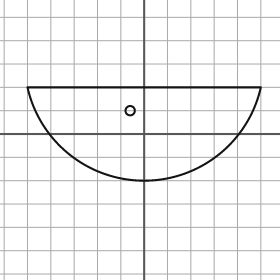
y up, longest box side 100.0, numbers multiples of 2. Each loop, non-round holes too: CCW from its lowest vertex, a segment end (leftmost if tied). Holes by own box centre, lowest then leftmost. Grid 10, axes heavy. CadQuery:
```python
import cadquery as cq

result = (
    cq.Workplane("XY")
    .moveTo(-50.0, 20.0)
    .threePointArc((0.0, -20.0), (50.0, 20.0))
    .close()
    .moveTo(-6.0, 10.0)
    .circle(2.0)
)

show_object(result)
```